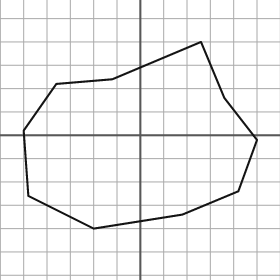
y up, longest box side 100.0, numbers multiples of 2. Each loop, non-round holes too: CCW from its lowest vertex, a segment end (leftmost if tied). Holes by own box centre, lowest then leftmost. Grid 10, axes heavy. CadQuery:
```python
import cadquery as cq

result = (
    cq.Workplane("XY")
    .moveTo(-20.0, -40.0)
    .lineTo(18.0, -34.0)
    .lineTo(42.0, -24.0)
    .lineTo(50.0, -2.0)
    .lineTo(36.0, 16.0)
    .lineTo(26.0, 40.0)
    .lineTo(-12.0, 24.0)
    .lineTo(-36.0, 22.0)
    .lineTo(-50.0, 2.0)
    .lineTo(-48.0, -26.0)
    .close()
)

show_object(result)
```